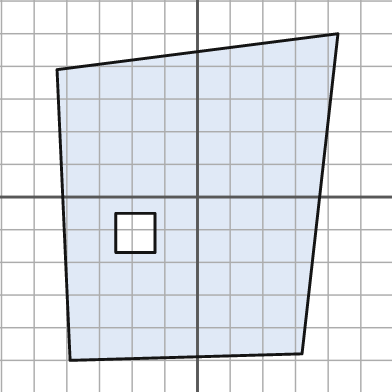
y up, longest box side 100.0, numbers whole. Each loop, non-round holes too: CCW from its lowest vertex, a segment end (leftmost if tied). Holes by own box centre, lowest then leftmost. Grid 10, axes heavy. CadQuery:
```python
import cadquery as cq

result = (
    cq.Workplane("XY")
    .moveTo(-39.0, -50.0)
    .lineTo(32.0, -48.0)
    .lineTo(43.0, 50.0)
    .lineTo(-43.0, 39.0)
    .close()
    .moveTo(-25.0, -17.0)
    .lineTo(-13.0, -17.0)
    .lineTo(-13.0, -5.0)
    .lineTo(-25.0, -5.0)
    .close()
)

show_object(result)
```